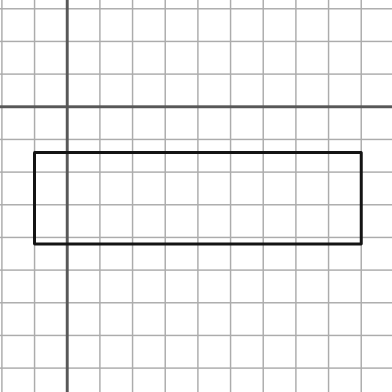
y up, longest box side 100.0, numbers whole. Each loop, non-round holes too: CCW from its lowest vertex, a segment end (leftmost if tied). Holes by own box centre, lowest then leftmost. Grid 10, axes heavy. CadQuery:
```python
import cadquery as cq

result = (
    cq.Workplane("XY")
    .moveTo(-10.0, -42.0)
    .lineTo(90.0, -42.0)
    .lineTo(90.0, -14.0)
    .lineTo(-10.0, -14.0)
    .close()
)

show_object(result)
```